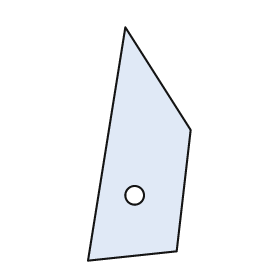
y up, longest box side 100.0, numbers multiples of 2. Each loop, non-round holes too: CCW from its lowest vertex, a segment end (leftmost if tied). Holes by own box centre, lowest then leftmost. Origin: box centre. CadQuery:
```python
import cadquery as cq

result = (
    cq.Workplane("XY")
    .moveTo(-22.0, -50.0)
    .lineTo(16.0, -46.0)
    .lineTo(22.0, 6.0)
    .lineTo(-6.0, 50.0)
    .close()
    .moveTo(-2.0, -22.0)
    .circle(4.0)
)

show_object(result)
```